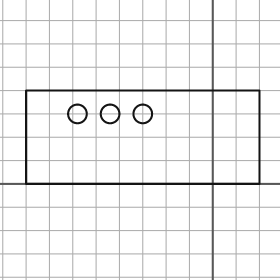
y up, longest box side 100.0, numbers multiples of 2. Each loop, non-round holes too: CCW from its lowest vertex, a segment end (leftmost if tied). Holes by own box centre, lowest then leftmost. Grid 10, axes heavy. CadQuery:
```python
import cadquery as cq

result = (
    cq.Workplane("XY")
    .moveTo(-80.0, 0.0)
    .lineTo(20.0, 0.0)
    .lineTo(20.0, 40.0)
    .lineTo(-80.0, 40.0)
    .close()
    .moveTo(-58.0, 30.0)
    .circle(4.0)
    .moveTo(-44.0, 30.0)
    .circle(4.0)
    .moveTo(-30.0, 30.0)
    .circle(4.0)
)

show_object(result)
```